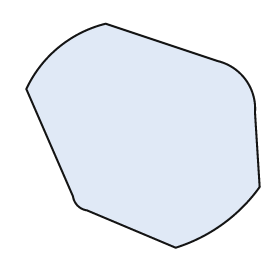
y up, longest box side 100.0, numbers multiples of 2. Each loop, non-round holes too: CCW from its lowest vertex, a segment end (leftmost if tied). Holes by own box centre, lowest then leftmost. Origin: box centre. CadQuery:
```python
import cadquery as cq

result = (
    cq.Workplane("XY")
    .moveTo(14.0, -48.0)
    .threePointArc((34.0, -38.0), (50.0, -22.0))
    .lineTo(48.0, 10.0)
    .threePointArc((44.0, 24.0), (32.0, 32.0))
    .lineTo(-16.0, 48.0)
    .threePointArc((-36.0, 38.0), (-50.0, 20.0))
    .lineTo(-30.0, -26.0)
    .threePointArc((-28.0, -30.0), (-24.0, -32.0))
    .close()
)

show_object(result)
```